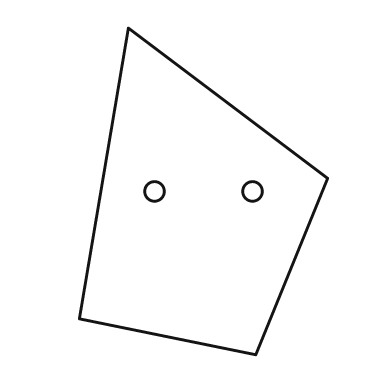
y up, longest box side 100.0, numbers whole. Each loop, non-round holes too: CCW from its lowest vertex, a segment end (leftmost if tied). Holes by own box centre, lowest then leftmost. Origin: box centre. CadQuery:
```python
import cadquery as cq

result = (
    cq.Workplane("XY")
    .moveTo(16.0, -50.0)
    .lineTo(38.0, 4.0)
    .lineTo(-23.0, 50.0)
    .lineTo(-38.0, -39.0)
    .close()
    .moveTo(-15.0, 0.0)
    .circle(3.0)
    .moveTo(15.0, 0.0)
    .circle(3.0)
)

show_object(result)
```